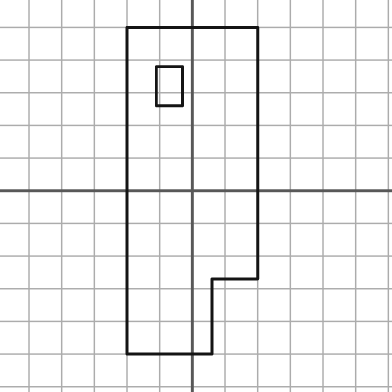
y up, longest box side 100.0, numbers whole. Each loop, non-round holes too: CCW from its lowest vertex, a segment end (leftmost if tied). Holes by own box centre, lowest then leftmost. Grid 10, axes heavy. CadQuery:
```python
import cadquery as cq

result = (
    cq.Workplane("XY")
    .moveTo(-20.0, -50.0)
    .lineTo(6.0, -50.0)
    .lineTo(6.0, -27.0)
    .lineTo(20.0, -27.0)
    .lineTo(20.0, 50.0)
    .lineTo(-20.0, 50.0)
    .close()
    .moveTo(-11.0, 26.0)
    .lineTo(-3.0, 26.0)
    .lineTo(-3.0, 38.0)
    .lineTo(-11.0, 38.0)
    .close()
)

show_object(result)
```